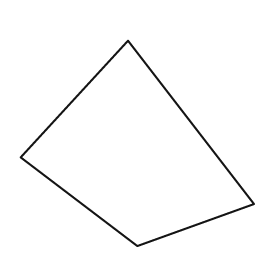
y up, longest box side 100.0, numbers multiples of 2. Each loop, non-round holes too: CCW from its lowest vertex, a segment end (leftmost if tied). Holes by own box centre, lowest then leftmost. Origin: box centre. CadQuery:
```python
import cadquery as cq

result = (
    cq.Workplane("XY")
    .moveTo(0.0, -44.0)
    .lineTo(50.0, -26.0)
    .lineTo(-4.0, 44.0)
    .lineTo(-50.0, -6.0)
    .close()
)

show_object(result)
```